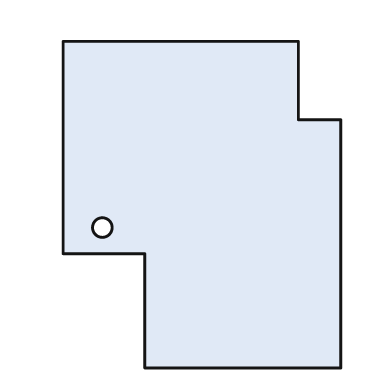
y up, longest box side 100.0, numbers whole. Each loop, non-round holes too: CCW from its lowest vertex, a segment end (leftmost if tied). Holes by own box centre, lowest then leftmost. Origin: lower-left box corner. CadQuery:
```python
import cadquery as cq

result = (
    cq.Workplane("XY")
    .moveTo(25.0, 0.0)
    .lineTo(85.0, 0.0)
    .lineTo(85.0, 76.0)
    .lineTo(72.0, 76.0)
    .lineTo(72.0, 100.0)
    .lineTo(0.0, 100.0)
    .lineTo(0.0, 35.0)
    .lineTo(25.0, 35.0)
    .close()
    .moveTo(12.0, 43.0)
    .circle(3.0)
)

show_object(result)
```